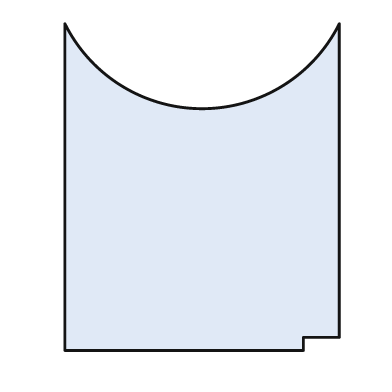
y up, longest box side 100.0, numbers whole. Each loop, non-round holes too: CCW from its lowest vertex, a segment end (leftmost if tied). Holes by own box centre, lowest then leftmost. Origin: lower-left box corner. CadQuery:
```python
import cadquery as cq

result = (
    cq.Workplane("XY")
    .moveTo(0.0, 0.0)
    .lineTo(73.0, 0.0)
    .lineTo(73.0, 4.0)
    .lineTo(84.0, 4.0)
    .lineTo(84.0, 100.0)
    .threePointArc((42.0, 74.0), (0.0, 100.0))
    .close()
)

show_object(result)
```